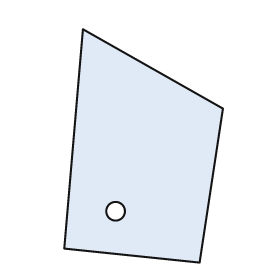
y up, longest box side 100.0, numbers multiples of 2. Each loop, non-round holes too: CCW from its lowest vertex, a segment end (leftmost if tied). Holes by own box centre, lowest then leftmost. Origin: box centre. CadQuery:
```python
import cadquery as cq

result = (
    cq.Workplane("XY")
    .moveTo(24.0, -50.0)
    .lineTo(34.0, 16.0)
    .lineTo(-26.0, 50.0)
    .lineTo(-34.0, -44.0)
    .close()
    .moveTo(-12.0, -28.0)
    .circle(4.0)
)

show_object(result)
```